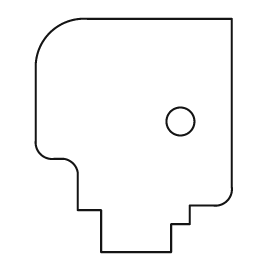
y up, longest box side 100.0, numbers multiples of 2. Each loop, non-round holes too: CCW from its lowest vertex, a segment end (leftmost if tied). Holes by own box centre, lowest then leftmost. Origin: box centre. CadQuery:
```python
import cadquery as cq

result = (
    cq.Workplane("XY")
    .moveTo(-14.0, -50.0)
    .lineTo(16.0, -50.0)
    .lineTo(16.0, -38.0)
    .lineTo(24.0, -38.0)
    .lineTo(24.0, -30.0)
    .lineTo(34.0, -30.0)
    .threePointArc((40.0, -28.0), (42.0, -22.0))
    .lineTo(42.0, 50.0)
    .lineTo(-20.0, 50.0)
    .threePointArc((-36.0, 44.0), (-42.0, 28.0))
    .lineTo(-42.0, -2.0)
    .threePointArc((-40.0, -8.0), (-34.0, -10.0))
    .lineTo(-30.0, -10.0)
    .threePointArc((-26.0, -12.0), (-24.0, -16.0))
    .lineTo(-24.0, -32.0)
    .lineTo(-14.0, -32.0)
    .close()
    .moveTo(20.0, 6.0)
    .circle(6.0)
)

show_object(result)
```